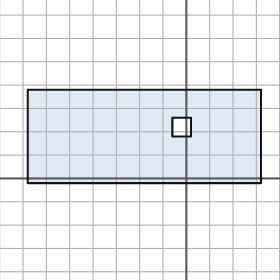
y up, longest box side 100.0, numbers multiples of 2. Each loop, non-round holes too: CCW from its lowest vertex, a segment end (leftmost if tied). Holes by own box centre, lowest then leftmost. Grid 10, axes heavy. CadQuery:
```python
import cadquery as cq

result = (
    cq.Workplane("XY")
    .moveTo(-68.0, -2.0)
    .lineTo(32.0, -2.0)
    .lineTo(32.0, 38.0)
    .lineTo(-68.0, 38.0)
    .close()
    .moveTo(-6.0, 18.0)
    .lineTo(2.0, 18.0)
    .lineTo(2.0, 26.0)
    .lineTo(-6.0, 26.0)
    .close()
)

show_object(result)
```